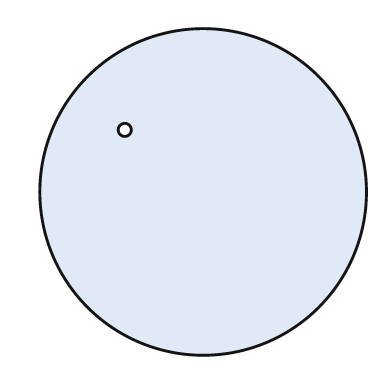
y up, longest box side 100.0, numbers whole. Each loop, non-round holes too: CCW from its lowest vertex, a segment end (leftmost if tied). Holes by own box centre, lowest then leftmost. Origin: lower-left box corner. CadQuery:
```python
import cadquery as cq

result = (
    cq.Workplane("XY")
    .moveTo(50.0, 50.0)
    .circle(50.0)
    .moveTo(26.0, 69.0)
    .circle(2.0)
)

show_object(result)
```